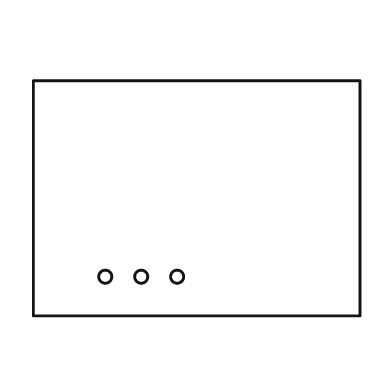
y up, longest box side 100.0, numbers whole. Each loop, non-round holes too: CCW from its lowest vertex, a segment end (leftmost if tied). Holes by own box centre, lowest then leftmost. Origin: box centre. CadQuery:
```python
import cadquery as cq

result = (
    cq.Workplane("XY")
    .moveTo(-50.0, -36.0)
    .lineTo(50.0, -36.0)
    .lineTo(50.0, 36.0)
    .lineTo(-50.0, 36.0)
    .close()
    .moveTo(-28.0, -24.0)
    .circle(2.0)
    .moveTo(-17.0, -24.0)
    .circle(2.0)
    .moveTo(-6.0, -24.0)
    .circle(2.0)
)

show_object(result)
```